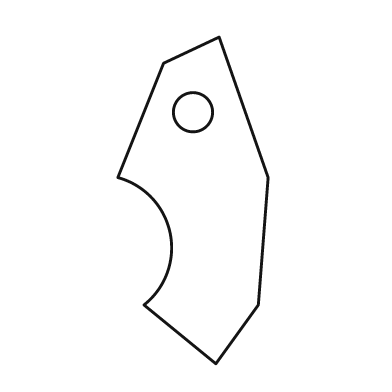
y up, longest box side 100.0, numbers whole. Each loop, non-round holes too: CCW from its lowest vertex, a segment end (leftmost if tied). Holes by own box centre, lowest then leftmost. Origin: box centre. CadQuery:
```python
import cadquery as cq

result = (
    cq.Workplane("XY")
    .moveTo(7.0, -50.0)
    .lineTo(20.0, -32.0)
    .lineTo(23.0, 7.0)
    .lineTo(8.0, 50.0)
    .lineTo(-9.0, 42.0)
    .lineTo(-23.0, 7.0)
    .threePointArc((-7.0, -10.0), (-15.0, -32.0))
    .close()
    .moveTo(0.0, 27.0)
    .circle(6.0)
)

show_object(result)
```